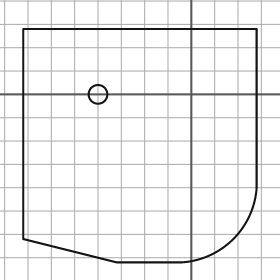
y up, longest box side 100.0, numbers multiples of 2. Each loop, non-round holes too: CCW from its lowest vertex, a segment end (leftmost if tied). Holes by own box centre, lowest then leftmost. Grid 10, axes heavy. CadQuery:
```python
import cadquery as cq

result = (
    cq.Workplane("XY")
    .moveTo(-32.0, -72.0)
    .lineTo(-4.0, -72.0)
    .threePointArc((18.0, -62.0), (28.0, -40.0))
    .lineTo(28.0, 28.0)
    .lineTo(-72.0, 28.0)
    .lineTo(-72.0, -62.0)
    .close()
    .moveTo(-40.0, 0.0)
    .circle(4.0)
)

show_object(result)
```